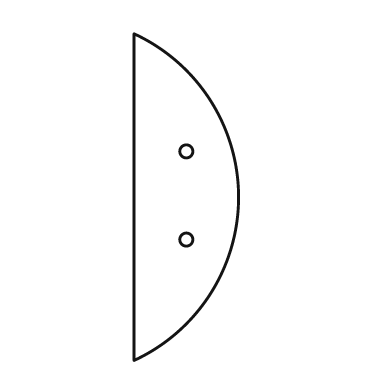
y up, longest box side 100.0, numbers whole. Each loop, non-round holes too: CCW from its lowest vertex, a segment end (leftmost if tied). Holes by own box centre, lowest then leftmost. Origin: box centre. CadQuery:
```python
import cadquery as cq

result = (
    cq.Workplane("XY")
    .moveTo(-16.0, -50.0)
    .threePointArc((16.0, 0.0), (-16.0, 50.0))
    .close()
    .moveTo(0.0, -13.0)
    .circle(2.0)
    .moveTo(0.0, 14.0)
    .circle(2.0)
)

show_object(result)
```